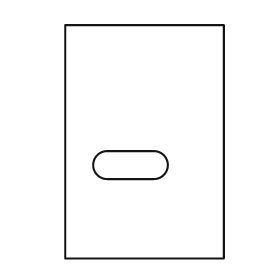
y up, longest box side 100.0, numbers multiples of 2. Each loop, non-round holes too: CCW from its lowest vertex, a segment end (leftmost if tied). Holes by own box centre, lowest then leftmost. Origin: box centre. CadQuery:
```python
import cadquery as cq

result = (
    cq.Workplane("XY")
    .moveTo(-34.0, -50.0)
    .lineTo(34.0, -50.0)
    .lineTo(34.0, 50.0)
    .lineTo(-34.0, 50.0)
    .close()
    .moveTo(-16.0, -16.0)
    .lineTo(4.0, -16.0)
    .threePointArc((10.0, -10.0), (4.0, -4.0))
    .lineTo(-16.0, -4.0)
    .threePointArc((-22.0, -10.0), (-16.0, -16.0))
    .close()
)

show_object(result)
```